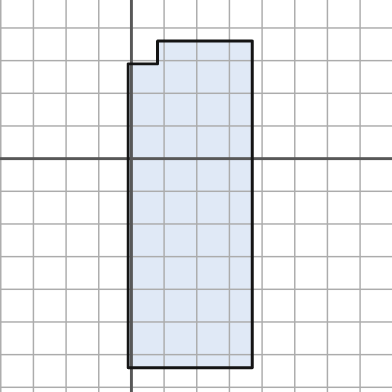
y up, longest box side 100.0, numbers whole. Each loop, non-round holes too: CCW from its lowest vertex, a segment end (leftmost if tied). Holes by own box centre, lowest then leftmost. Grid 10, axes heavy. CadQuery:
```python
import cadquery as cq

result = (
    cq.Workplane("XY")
    .moveTo(-1.0, -64.0)
    .lineTo(37.0, -64.0)
    .lineTo(37.0, 36.0)
    .lineTo(8.0, 36.0)
    .lineTo(8.0, 29.0)
    .lineTo(-1.0, 29.0)
    .close()
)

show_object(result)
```